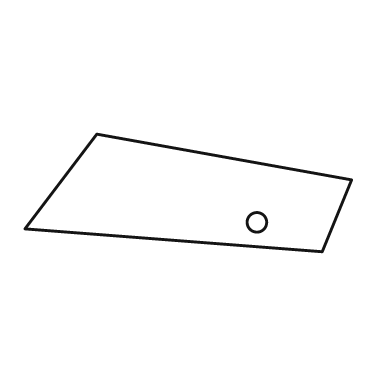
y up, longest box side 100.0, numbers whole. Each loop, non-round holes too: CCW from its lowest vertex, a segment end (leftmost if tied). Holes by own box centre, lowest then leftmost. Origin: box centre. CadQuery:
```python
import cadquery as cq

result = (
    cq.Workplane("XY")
    .moveTo(41.0, -18.0)
    .lineTo(50.0, 4.0)
    .lineTo(-28.0, 18.0)
    .lineTo(-50.0, -11.0)
    .close()
    .moveTo(21.0, -9.0)
    .circle(3.0)
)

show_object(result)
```